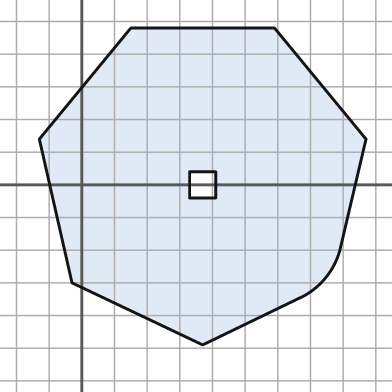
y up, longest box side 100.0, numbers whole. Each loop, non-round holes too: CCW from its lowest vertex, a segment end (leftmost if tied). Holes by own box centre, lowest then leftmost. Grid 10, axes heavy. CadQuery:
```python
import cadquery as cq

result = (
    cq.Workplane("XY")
    .moveTo(37.0, -49.0)
    .lineTo(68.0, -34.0)
    .threePointArc((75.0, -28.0), (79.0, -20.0))
    .lineTo(87.0, 14.0)
    .lineTo(59.0, 48.0)
    .lineTo(15.0, 48.0)
    .lineTo(-13.0, 14.0)
    .lineTo(-3.0, -30.0)
    .close()
    .moveTo(33.0, -4.0)
    .lineTo(41.0, -4.0)
    .lineTo(41.0, 4.0)
    .lineTo(33.0, 4.0)
    .close()
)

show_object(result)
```